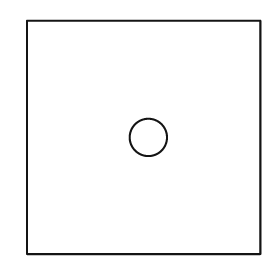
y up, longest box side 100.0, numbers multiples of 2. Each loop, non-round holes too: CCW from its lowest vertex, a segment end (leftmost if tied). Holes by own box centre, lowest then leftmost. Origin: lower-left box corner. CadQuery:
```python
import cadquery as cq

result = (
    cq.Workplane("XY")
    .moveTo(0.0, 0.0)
    .lineTo(100.0, 0.0)
    .lineTo(100.0, 100.0)
    .lineTo(0.0, 100.0)
    .close()
    .moveTo(52.0, 50.0)
    .circle(8.0)
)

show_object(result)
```